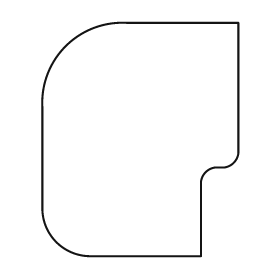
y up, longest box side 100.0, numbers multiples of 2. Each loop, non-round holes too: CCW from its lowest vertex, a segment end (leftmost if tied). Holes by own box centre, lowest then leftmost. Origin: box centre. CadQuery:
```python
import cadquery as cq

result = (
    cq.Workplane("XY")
    .moveTo(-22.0, -50.0)
    .lineTo(26.0, -50.0)
    .lineTo(26.0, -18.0)
    .threePointArc((28.0, -14.0), (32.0, -12.0))
    .lineTo(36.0, -12.0)
    .threePointArc((40.0, -10.0), (42.0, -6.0))
    .lineTo(42.0, 50.0)
    .lineTo(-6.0, 50.0)
    .threePointArc((-32.0, 40.0), (-42.0, 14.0))
    .lineTo(-42.0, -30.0)
    .threePointArc((-36.0, -44.0), (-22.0, -50.0))
    .close()
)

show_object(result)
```